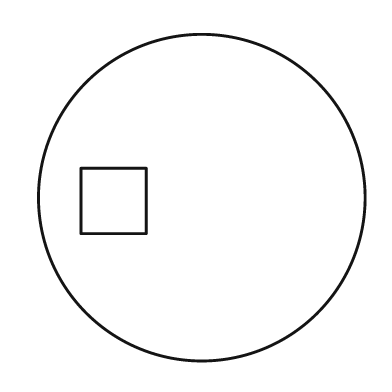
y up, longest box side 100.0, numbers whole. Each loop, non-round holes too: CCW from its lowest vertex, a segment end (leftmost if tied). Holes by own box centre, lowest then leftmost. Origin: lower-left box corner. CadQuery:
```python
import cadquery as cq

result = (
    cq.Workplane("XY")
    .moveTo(50.0, 50.0)
    .circle(50.0)
    .moveTo(13.0, 39.0)
    .lineTo(33.0, 39.0)
    .lineTo(33.0, 59.0)
    .lineTo(13.0, 59.0)
    .close()
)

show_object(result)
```